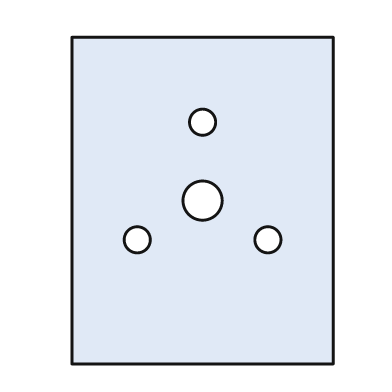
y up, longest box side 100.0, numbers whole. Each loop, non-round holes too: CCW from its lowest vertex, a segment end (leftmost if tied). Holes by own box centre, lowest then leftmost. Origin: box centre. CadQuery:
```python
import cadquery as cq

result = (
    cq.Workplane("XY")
    .moveTo(-40.0, -50.0)
    .lineTo(40.0, -50.0)
    .lineTo(40.0, 50.0)
    .lineTo(-40.0, 50.0)
    .close()
    .moveTo(-20.0, -12.0)
    .circle(4.0)
    .moveTo(20.0, -12.0)
    .circle(4.0)
    .moveTo(0.0, 0.0)
    .circle(6.0)
    .moveTo(0.0, 24.0)
    .circle(4.0)
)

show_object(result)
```